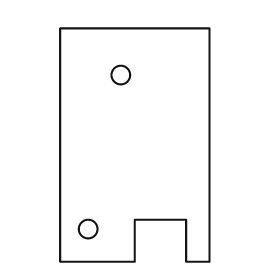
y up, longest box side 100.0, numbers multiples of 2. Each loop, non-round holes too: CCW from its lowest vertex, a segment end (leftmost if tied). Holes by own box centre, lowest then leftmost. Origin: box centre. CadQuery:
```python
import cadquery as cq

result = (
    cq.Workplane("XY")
    .moveTo(-32.0, -50.0)
    .lineTo(0.0, -50.0)
    .lineTo(0.0, -32.0)
    .lineTo(22.0, -32.0)
    .lineTo(22.0, -50.0)
    .lineTo(32.0, -50.0)
    .lineTo(32.0, 50.0)
    .lineTo(-32.0, 50.0)
    .close()
    .moveTo(-20.0, -36.0)
    .circle(4.0)
    .moveTo(-6.0, 30.0)
    .circle(4.0)
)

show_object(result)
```